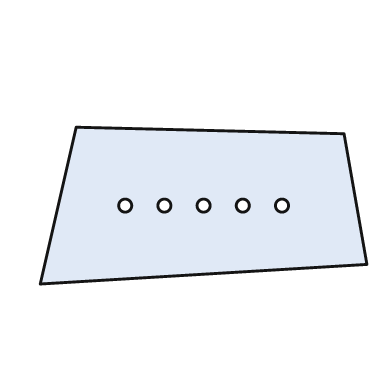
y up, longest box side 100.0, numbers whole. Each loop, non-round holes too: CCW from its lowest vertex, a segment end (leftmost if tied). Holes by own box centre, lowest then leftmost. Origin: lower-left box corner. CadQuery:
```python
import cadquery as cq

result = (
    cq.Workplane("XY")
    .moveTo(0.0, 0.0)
    .lineTo(100.0, 6.0)
    .lineTo(93.0, 46.0)
    .lineTo(11.0, 48.0)
    .close()
    .moveTo(26.0, 24.0)
    .circle(2.0)
    .moveTo(38.0, 24.0)
    .circle(2.0)
    .moveTo(50.0, 24.0)
    .circle(2.0)
    .moveTo(62.0, 24.0)
    .circle(2.0)
    .moveTo(74.0, 24.0)
    .circle(2.0)
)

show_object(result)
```